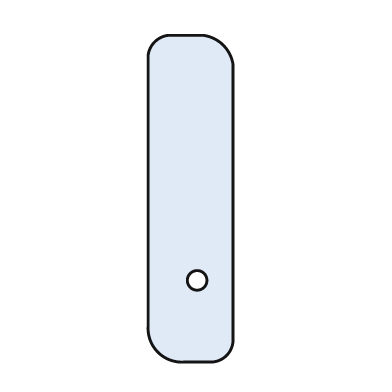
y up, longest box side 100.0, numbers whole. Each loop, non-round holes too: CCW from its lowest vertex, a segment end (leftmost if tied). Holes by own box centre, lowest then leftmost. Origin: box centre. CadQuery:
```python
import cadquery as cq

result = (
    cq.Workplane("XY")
    .moveTo(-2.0, -50.0)
    .lineTo(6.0, -50.0)
    .threePointArc((11.0, -48.0), (13.0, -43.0))
    .lineTo(13.0, 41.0)
    .threePointArc((10.0, 47.0), (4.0, 50.0))
    .lineTo(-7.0, 50.0)
    .threePointArc((-11.0, 48.0), (-13.0, 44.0))
    .lineTo(-13.0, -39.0)
    .threePointArc((-10.0, -47.0), (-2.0, -50.0))
    .close()
    .moveTo(2.0, -25.0)
    .circle(3.0)
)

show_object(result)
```